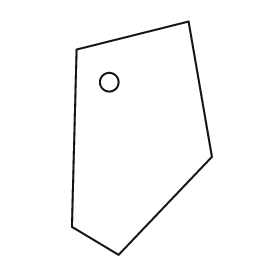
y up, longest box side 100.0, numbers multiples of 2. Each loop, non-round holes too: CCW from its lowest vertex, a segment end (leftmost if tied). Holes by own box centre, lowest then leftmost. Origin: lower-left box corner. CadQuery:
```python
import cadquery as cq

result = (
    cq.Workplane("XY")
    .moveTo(20.0, 0.0)
    .lineTo(60.0, 42.0)
    .lineTo(50.0, 100.0)
    .lineTo(2.0, 88.0)
    .lineTo(0.0, 12.0)
    .close()
    .moveTo(16.0, 74.0)
    .circle(4.0)
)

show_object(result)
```